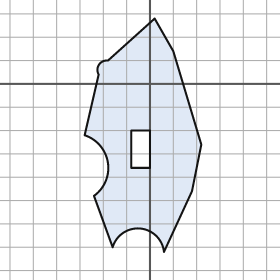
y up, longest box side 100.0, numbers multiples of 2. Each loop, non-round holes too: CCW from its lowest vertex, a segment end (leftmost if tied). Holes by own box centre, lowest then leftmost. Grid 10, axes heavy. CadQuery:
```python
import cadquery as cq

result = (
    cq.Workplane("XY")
    .moveTo(6.0, -72.0)
    .lineTo(18.0, -46.0)
    .lineTo(22.0, -26.0)
    .lineTo(10.0, 14.0)
    .lineTo(2.0, 28.0)
    .lineTo(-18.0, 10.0)
    .threePointArc((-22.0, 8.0), (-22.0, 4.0))
    .lineTo(-28.0, -22.0)
    .threePointArc((-18.0, -34.0), (-24.0, -48.0))
    .lineTo(-16.0, -70.0)
    .threePointArc((-4.0, -62.0), (6.0, -72.0))
    .close()
    .moveTo(-8.0, -36.0)
    .lineTo(0.0, -36.0)
    .lineTo(0.0, -20.0)
    .lineTo(-8.0, -20.0)
    .close()
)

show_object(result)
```